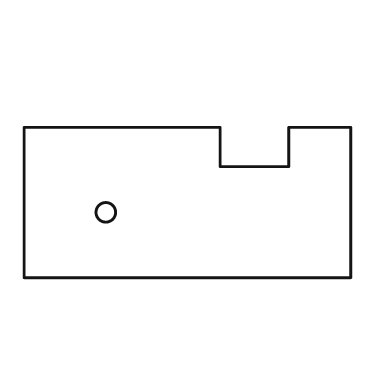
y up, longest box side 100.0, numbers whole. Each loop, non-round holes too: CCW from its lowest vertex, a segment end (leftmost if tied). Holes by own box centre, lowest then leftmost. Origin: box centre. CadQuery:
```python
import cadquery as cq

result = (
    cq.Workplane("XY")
    .moveTo(-50.0, -23.0)
    .lineTo(50.0, -23.0)
    .lineTo(50.0, 23.0)
    .lineTo(31.0, 23.0)
    .lineTo(31.0, 11.0)
    .lineTo(10.0, 11.0)
    .lineTo(10.0, 23.0)
    .lineTo(-50.0, 23.0)
    .close()
    .moveTo(-25.0, -3.0)
    .circle(3.0)
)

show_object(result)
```